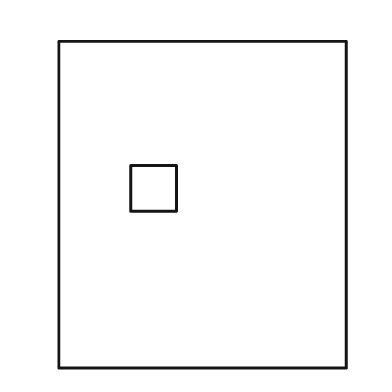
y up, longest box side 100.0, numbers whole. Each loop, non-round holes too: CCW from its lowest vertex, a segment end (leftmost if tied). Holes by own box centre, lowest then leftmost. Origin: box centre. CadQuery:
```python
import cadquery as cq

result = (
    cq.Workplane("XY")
    .moveTo(-44.0, -50.0)
    .lineTo(44.0, -50.0)
    .lineTo(44.0, 50.0)
    .lineTo(-44.0, 50.0)
    .close()
    .moveTo(-22.0, -2.0)
    .lineTo(-8.0, -2.0)
    .lineTo(-8.0, 12.0)
    .lineTo(-22.0, 12.0)
    .close()
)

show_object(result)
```